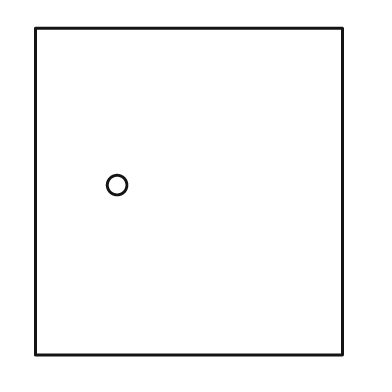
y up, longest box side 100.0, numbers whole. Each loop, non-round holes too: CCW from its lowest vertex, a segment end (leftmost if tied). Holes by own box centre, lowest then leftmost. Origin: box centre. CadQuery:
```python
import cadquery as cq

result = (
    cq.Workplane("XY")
    .moveTo(-47.0, -50.0)
    .lineTo(47.0, -50.0)
    .lineTo(47.0, 50.0)
    .lineTo(-47.0, 50.0)
    .close()
    .moveTo(-22.0, 2.0)
    .circle(3.0)
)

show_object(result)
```